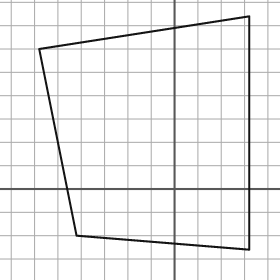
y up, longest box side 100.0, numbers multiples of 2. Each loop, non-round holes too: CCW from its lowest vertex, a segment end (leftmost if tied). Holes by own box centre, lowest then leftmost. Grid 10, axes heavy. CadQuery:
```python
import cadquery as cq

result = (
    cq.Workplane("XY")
    .moveTo(32.0, -26.0)
    .lineTo(32.0, 74.0)
    .lineTo(-58.0, 60.0)
    .lineTo(-42.0, -20.0)
    .close()
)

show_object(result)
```